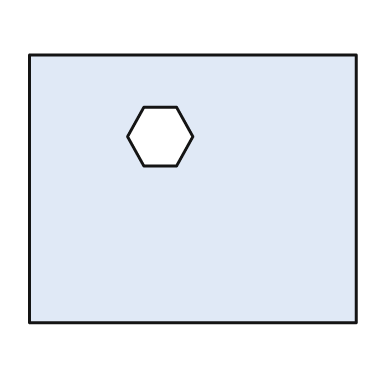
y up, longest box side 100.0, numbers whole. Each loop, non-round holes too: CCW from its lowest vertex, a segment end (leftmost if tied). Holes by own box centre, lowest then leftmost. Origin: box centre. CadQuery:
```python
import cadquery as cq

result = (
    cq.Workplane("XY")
    .moveTo(-50.0, -41.0)
    .lineTo(50.0, -41.0)
    .lineTo(50.0, 41.0)
    .lineTo(-50.0, 41.0)
    .close()
    .moveTo(-15.0, 7.0)
    .lineTo(-5.0, 7.0)
    .lineTo(0.0, 16.0)
    .lineTo(-5.0, 25.0)
    .lineTo(-15.0, 25.0)
    .lineTo(-20.0, 16.0)
    .close()
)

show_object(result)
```